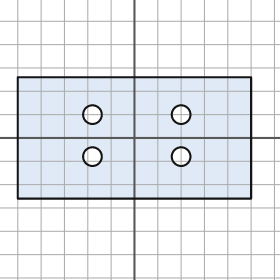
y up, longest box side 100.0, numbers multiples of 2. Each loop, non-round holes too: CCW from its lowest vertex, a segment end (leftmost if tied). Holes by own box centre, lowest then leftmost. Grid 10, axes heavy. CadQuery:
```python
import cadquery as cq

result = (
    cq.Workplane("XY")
    .moveTo(-50.0, -26.0)
    .lineTo(50.0, -26.0)
    .lineTo(50.0, 26.0)
    .lineTo(-50.0, 26.0)
    .close()
    .moveTo(-18.0, -8.0)
    .circle(4.0)
    .moveTo(20.0, -8.0)
    .circle(4.0)
    .moveTo(-18.0, 10.0)
    .circle(4.0)
    .moveTo(20.0, 10.0)
    .circle(4.0)
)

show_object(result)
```